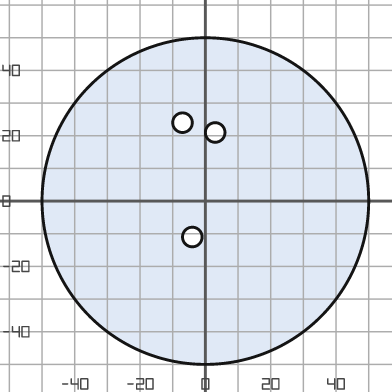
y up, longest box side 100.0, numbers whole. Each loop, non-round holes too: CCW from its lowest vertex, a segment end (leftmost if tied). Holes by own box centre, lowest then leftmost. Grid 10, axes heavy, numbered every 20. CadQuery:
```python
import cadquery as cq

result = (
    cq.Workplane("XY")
    .moveTo(0.0, 0.0)
    .circle(50.0)
    .moveTo(-4.0, -11.0)
    .circle(3.0)
    .moveTo(3.0, 21.0)
    .circle(3.0)
    .moveTo(-7.0, 24.0)
    .circle(3.0)
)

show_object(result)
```